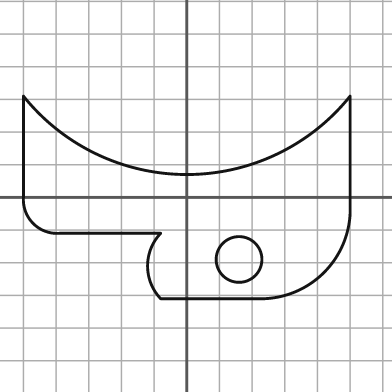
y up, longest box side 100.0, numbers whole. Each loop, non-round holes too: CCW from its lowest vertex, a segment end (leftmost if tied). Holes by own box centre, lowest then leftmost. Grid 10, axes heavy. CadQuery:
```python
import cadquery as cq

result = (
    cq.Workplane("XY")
    .moveTo(-8.0, -31.0)
    .lineTo(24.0, -31.0)
    .threePointArc((42.0, -23.0), (50.0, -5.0))
    .lineTo(50.0, 31.0)
    .threePointArc((0.0, 7.0), (-50.0, 31.0))
    .lineTo(-50.0, 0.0)
    .threePointArc((-47.0, -8.0), (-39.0, -11.0))
    .lineTo(-8.0, -11.0)
    .threePointArc((-12.0, -21.0), (-8.0, -31.0))
    .close()
    .moveTo(16.0, -19.0)
    .circle(7.0)
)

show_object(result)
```